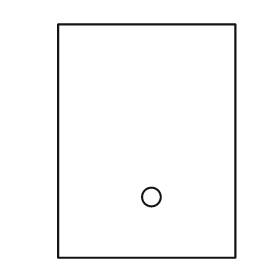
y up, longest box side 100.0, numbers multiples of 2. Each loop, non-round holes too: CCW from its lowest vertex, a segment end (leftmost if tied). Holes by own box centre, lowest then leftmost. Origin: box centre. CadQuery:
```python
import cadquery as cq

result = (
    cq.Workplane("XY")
    .moveTo(-38.0, -50.0)
    .lineTo(38.0, -50.0)
    .lineTo(38.0, 50.0)
    .lineTo(-38.0, 50.0)
    .close()
    .moveTo(2.0, -24.0)
    .circle(4.0)
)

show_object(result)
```